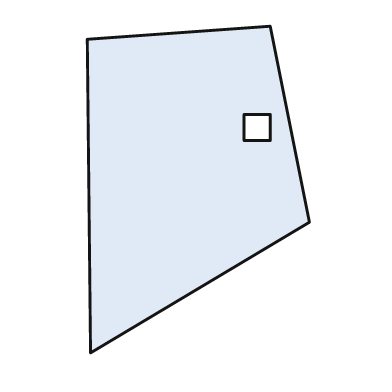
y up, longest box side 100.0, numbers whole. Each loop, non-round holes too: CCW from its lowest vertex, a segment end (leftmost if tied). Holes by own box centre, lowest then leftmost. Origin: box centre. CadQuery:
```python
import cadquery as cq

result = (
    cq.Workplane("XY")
    .moveTo(-33.0, -50.0)
    .lineTo(34.0, -10.0)
    .lineTo(22.0, 50.0)
    .lineTo(-34.0, 46.0)
    .close()
    .moveTo(14.0, 15.0)
    .lineTo(22.0, 15.0)
    .lineTo(22.0, 23.0)
    .lineTo(14.0, 23.0)
    .close()
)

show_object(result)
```